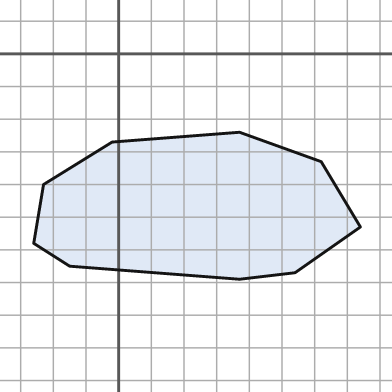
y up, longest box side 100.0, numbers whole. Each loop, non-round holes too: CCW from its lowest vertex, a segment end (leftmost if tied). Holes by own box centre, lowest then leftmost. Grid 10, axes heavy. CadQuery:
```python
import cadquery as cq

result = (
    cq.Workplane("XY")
    .moveTo(37.0, -69.0)
    .lineTo(54.0, -67.0)
    .lineTo(74.0, -53.0)
    .lineTo(62.0, -33.0)
    .lineTo(37.0, -24.0)
    .lineTo(-2.0, -27.0)
    .lineTo(-23.0, -40.0)
    .lineTo(-26.0, -58.0)
    .lineTo(-15.0, -65.0)
    .close()
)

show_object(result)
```